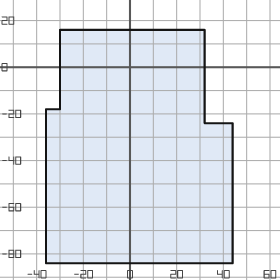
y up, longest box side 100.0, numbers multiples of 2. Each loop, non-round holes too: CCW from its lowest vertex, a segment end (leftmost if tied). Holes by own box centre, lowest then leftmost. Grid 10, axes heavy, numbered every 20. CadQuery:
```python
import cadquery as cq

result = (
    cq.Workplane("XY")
    .moveTo(-36.0, -84.0)
    .lineTo(44.0, -84.0)
    .lineTo(44.0, -24.0)
    .lineTo(32.0, -24.0)
    .lineTo(32.0, 16.0)
    .lineTo(-30.0, 16.0)
    .lineTo(-30.0, -18.0)
    .lineTo(-36.0, -18.0)
    .close()
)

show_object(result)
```